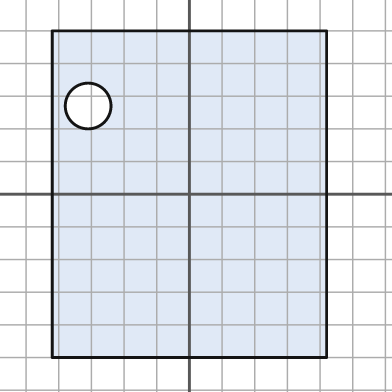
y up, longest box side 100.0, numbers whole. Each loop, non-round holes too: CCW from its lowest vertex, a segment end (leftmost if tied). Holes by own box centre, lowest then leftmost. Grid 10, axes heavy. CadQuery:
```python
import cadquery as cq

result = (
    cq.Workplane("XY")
    .moveTo(-42.0, -50.0)
    .lineTo(42.0, -50.0)
    .lineTo(42.0, 50.0)
    .lineTo(-42.0, 50.0)
    .close()
    .moveTo(-31.0, 27.0)
    .circle(7.0)
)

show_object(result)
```